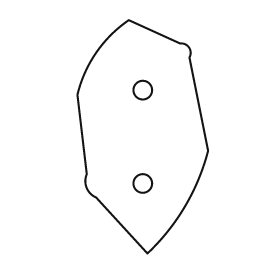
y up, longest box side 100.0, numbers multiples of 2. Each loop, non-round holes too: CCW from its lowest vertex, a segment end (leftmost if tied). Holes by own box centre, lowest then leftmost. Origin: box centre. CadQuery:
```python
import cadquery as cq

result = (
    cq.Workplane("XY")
    .moveTo(2.0, -50.0)
    .threePointArc((18.0, -30.0), (28.0, -6.0))
    .lineTo(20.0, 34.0)
    .threePointArc((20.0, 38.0), (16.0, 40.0))
    .lineTo(-6.0, 50.0)
    .threePointArc((-20.0, 36.0), (-28.0, 18.0))
    .lineTo(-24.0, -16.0)
    .threePointArc((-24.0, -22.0), (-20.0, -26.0))
    .close()
    .moveTo(0.0, -20.0)
    .circle(4.0)
    .moveTo(0.0, 20.0)
    .circle(4.0)
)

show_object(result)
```